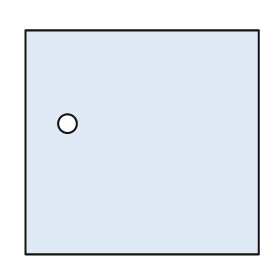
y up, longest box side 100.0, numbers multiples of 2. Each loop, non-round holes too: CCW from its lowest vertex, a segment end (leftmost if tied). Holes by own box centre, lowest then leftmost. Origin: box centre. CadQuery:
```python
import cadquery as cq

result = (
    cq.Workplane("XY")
    .moveTo(-50.0, -48.0)
    .lineTo(50.0, -48.0)
    .lineTo(50.0, 48.0)
    .lineTo(-50.0, 48.0)
    .close()
    .moveTo(-32.0, 8.0)
    .circle(4.0)
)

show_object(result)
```